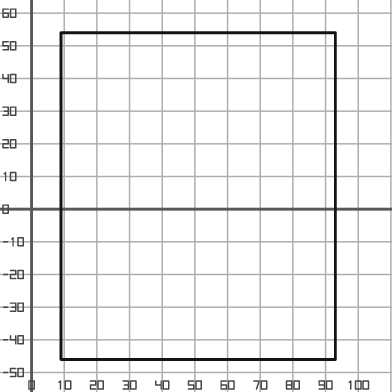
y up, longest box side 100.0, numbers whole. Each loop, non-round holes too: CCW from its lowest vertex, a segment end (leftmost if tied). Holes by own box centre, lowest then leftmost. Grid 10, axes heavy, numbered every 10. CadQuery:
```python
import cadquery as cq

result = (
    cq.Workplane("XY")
    .moveTo(9.0, -46.0)
    .lineTo(93.0, -46.0)
    .lineTo(93.0, 54.0)
    .lineTo(9.0, 54.0)
    .close()
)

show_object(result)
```